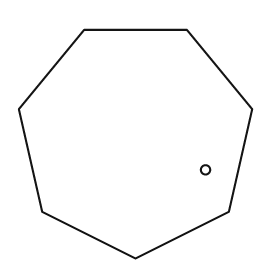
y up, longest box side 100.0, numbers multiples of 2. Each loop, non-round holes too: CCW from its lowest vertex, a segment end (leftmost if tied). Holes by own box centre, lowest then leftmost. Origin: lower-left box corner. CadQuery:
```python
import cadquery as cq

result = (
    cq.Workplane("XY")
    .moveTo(50.0, 0.0)
    .lineTo(90.0, 20.0)
    .lineTo(100.0, 64.0)
    .lineTo(72.0, 98.0)
    .lineTo(28.0, 98.0)
    .lineTo(0.0, 64.0)
    .lineTo(10.0, 20.0)
    .close()
    .moveTo(80.0, 38.0)
    .circle(2.0)
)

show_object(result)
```